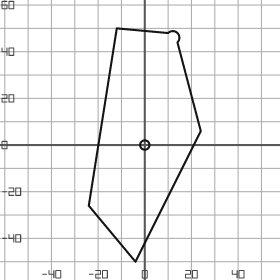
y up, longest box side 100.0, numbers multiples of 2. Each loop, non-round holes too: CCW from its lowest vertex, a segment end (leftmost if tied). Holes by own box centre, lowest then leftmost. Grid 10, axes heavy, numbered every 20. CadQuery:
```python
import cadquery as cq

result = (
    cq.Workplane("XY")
    .moveTo(-4.0, -50.0)
    .lineTo(24.0, 6.0)
    .lineTo(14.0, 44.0)
    .threePointArc((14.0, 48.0), (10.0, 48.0))
    .lineTo(-12.0, 50.0)
    .lineTo(-24.0, -26.0)
    .close()
    .moveTo(0.0, 0.0)
    .circle(2.0)
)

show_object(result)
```